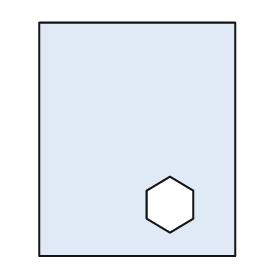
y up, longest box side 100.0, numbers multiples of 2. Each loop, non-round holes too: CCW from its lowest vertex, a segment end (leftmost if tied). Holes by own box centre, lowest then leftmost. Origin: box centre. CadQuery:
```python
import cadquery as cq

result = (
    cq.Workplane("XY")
    .moveTo(-42.0, -50.0)
    .lineTo(42.0, -50.0)
    .lineTo(42.0, 50.0)
    .lineTo(-42.0, 50.0)
    .close()
    .moveTo(14.0, -40.0)
    .lineTo(24.0, -34.0)
    .lineTo(24.0, -22.0)
    .lineTo(14.0, -16.0)
    .lineTo(4.0, -22.0)
    .lineTo(4.0, -34.0)
    .close()
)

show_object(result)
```